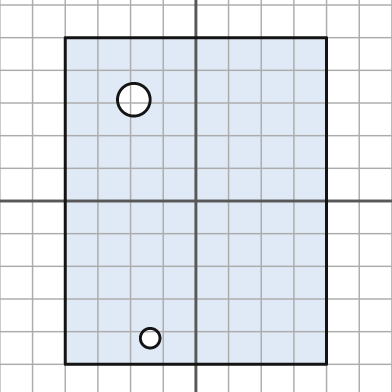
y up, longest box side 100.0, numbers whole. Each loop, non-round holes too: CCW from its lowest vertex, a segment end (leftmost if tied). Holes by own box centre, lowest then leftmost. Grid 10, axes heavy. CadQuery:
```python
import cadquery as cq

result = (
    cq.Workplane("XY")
    .moveTo(-40.0, -50.0)
    .lineTo(40.0, -50.0)
    .lineTo(40.0, 50.0)
    .lineTo(-40.0, 50.0)
    .close()
    .moveTo(-14.0, -42.0)
    .circle(3.0)
    .moveTo(-19.0, 31.0)
    .circle(5.0)
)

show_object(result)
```